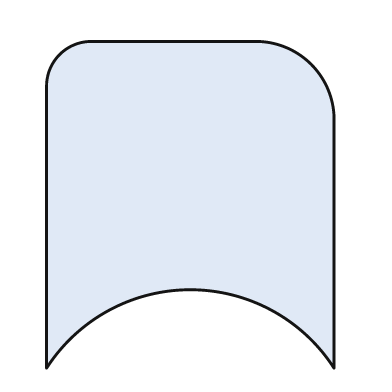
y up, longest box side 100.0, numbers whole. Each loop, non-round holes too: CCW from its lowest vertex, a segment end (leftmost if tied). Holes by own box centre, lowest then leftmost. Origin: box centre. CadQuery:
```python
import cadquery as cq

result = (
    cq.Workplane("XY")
    .moveTo(-44.0, -50.0)
    .threePointArc((0.0, -26.0), (44.0, -50.0))
    .lineTo(44.0, 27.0)
    .threePointArc((37.0, 43.0), (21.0, 50.0))
    .lineTo(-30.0, 50.0)
    .threePointArc((-40.0, 46.0), (-44.0, 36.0))
    .close()
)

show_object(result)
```